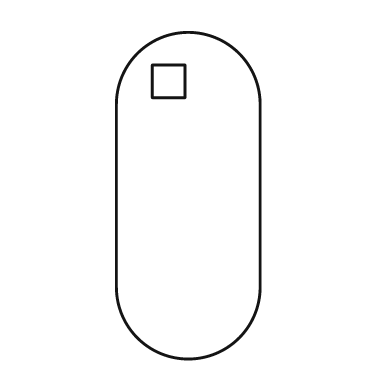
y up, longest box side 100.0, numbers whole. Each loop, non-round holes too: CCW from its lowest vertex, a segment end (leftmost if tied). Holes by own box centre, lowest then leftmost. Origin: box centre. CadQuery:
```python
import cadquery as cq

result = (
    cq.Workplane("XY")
    .moveTo(-22.0, -28.0)
    .threePointArc((0.0, -50.0), (22.0, -28.0))
    .lineTo(22.0, 28.0)
    .threePointArc((0.0, 50.0), (-22.0, 28.0))
    .close()
    .moveTo(-11.0, 30.0)
    .lineTo(-1.0, 30.0)
    .lineTo(-1.0, 40.0)
    .lineTo(-11.0, 40.0)
    .close()
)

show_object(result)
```